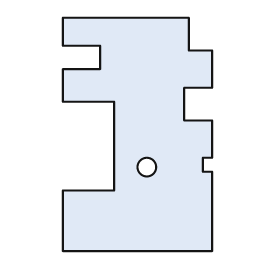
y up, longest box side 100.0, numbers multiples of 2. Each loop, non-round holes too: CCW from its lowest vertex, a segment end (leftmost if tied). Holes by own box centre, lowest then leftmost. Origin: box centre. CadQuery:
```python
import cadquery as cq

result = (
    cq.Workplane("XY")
    .moveTo(-32.0, -50.0)
    .lineTo(32.0, -50.0)
    .lineTo(32.0, -16.0)
    .lineTo(28.0, -16.0)
    .lineTo(28.0, -10.0)
    .lineTo(32.0, -10.0)
    .lineTo(32.0, 6.0)
    .lineTo(20.0, 6.0)
    .lineTo(20.0, 20.0)
    .lineTo(32.0, 20.0)
    .lineTo(32.0, 36.0)
    .lineTo(22.0, 36.0)
    .lineTo(22.0, 50.0)
    .lineTo(-32.0, 50.0)
    .lineTo(-32.0, 38.0)
    .lineTo(-16.0, 38.0)
    .lineTo(-16.0, 28.0)
    .lineTo(-32.0, 28.0)
    .lineTo(-32.0, 14.0)
    .lineTo(-10.0, 14.0)
    .lineTo(-10.0, -24.0)
    .lineTo(-32.0, -24.0)
    .close()
    .moveTo(4.0, -14.0)
    .circle(4.0)
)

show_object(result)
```